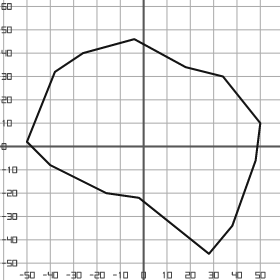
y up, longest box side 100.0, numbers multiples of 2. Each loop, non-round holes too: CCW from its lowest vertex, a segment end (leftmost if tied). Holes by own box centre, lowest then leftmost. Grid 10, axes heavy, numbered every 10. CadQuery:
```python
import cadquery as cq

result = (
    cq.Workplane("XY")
    .moveTo(28.0, -46.0)
    .lineTo(38.0, -34.0)
    .lineTo(48.0, -6.0)
    .lineTo(50.0, 10.0)
    .lineTo(34.0, 30.0)
    .lineTo(18.0, 34.0)
    .lineTo(-4.0, 46.0)
    .lineTo(-26.0, 40.0)
    .lineTo(-38.0, 32.0)
    .lineTo(-50.0, 2.0)
    .lineTo(-40.0, -8.0)
    .lineTo(-16.0, -20.0)
    .lineTo(-2.0, -22.0)
    .close()
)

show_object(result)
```